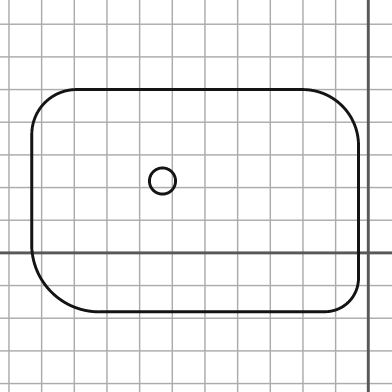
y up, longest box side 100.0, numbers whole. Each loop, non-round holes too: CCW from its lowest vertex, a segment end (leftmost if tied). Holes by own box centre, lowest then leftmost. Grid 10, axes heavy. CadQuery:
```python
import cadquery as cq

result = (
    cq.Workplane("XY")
    .moveTo(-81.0, -18.0)
    .lineTo(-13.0, -18.0)
    .threePointArc((-6.0, -15.0), (-3.0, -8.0))
    .lineTo(-3.0, 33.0)
    .threePointArc((-8.0, 45.0), (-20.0, 50.0))
    .lineTo(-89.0, 50.0)
    .threePointArc((-99.0, 46.0), (-103.0, 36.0))
    .lineTo(-103.0, 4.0)
    .threePointArc((-97.0, -12.0), (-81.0, -18.0))
    .close()
    .moveTo(-63.0, 22.0)
    .circle(4.0)
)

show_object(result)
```